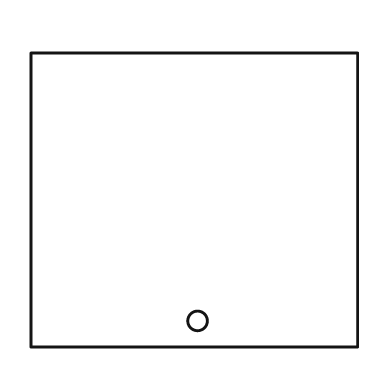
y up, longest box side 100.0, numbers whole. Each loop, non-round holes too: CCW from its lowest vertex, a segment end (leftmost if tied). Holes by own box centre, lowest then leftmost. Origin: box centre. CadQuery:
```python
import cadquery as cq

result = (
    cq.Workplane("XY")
    .moveTo(-50.0, -45.0)
    .lineTo(50.0, -45.0)
    .lineTo(50.0, 45.0)
    .lineTo(-50.0, 45.0)
    .close()
    .moveTo(1.0, -37.0)
    .circle(3.0)
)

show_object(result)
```